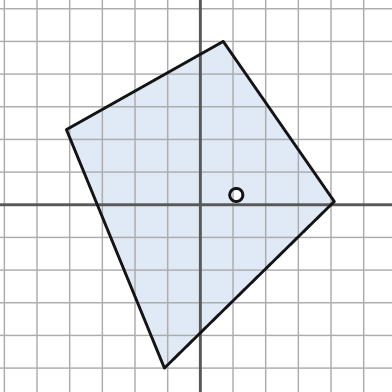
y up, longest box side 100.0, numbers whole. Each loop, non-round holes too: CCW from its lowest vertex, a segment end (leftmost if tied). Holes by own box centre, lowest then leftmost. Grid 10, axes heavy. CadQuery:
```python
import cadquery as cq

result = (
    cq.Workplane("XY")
    .moveTo(-11.0, -50.0)
    .lineTo(41.0, 1.0)
    .lineTo(7.0, 50.0)
    .lineTo(-41.0, 23.0)
    .close()
    .moveTo(11.0, 3.0)
    .circle(2.0)
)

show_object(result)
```